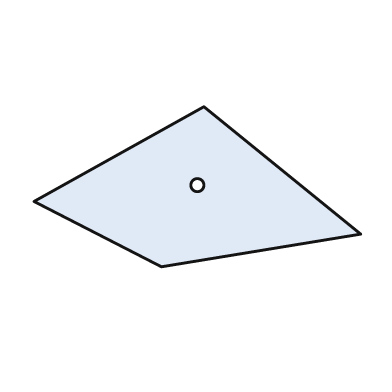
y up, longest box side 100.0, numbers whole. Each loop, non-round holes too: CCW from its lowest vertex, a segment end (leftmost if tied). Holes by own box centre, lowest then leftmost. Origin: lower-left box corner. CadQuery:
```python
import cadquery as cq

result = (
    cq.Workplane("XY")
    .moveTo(39.0, 0.0)
    .lineTo(100.0, 10.0)
    .lineTo(52.0, 49.0)
    .lineTo(0.0, 20.0)
    .close()
    .moveTo(50.0, 25.0)
    .circle(2.0)
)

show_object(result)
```